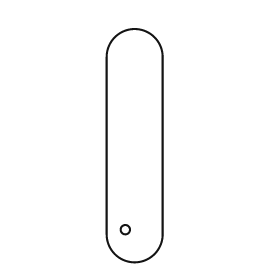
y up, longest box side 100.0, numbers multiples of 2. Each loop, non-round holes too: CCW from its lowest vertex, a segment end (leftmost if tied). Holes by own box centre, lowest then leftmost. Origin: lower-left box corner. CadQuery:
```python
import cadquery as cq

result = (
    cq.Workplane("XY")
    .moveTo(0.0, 12.0)
    .threePointArc((12.0, 0.0), (24.0, 12.0))
    .lineTo(24.0, 88.0)
    .threePointArc((12.0, 100.0), (0.0, 88.0))
    .close()
    .moveTo(8.0, 14.0)
    .circle(2.0)
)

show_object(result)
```